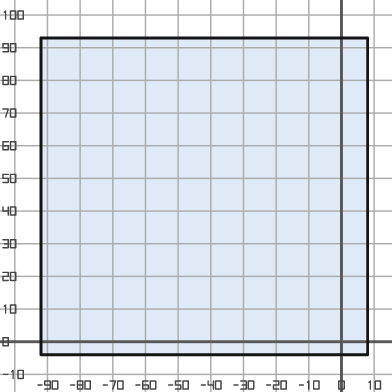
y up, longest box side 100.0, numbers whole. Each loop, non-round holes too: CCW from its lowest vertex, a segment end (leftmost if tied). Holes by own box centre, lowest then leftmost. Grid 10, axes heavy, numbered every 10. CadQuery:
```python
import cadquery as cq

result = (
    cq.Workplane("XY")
    .moveTo(-92.0, -4.0)
    .lineTo(8.0, -4.0)
    .lineTo(8.0, 93.0)
    .lineTo(-92.0, 93.0)
    .close()
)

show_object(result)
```